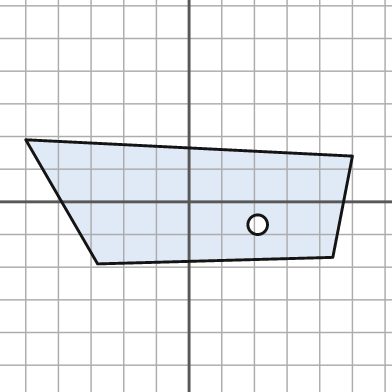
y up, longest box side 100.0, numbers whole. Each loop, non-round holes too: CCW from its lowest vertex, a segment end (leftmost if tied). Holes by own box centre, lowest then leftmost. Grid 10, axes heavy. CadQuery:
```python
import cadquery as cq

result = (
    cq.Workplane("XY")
    .moveTo(-28.0, -19.0)
    .lineTo(44.0, -17.0)
    .lineTo(50.0, 14.0)
    .lineTo(-50.0, 19.0)
    .close()
    .moveTo(21.0, -7.0)
    .circle(3.0)
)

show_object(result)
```